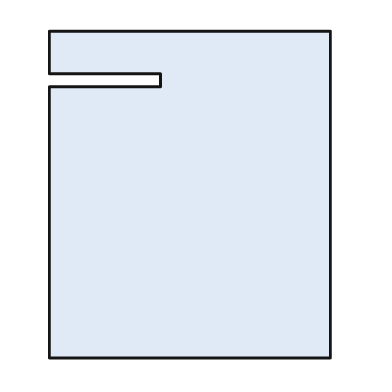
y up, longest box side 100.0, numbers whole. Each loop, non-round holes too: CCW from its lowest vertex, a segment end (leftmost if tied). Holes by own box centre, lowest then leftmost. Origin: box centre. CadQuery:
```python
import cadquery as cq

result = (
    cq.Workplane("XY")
    .moveTo(-43.0, -50.0)
    .lineTo(43.0, -50.0)
    .lineTo(43.0, 50.0)
    .lineTo(-43.0, 50.0)
    .lineTo(-43.0, 37.0)
    .lineTo(-9.0, 37.0)
    .lineTo(-9.0, 33.0)
    .lineTo(-43.0, 33.0)
    .close()
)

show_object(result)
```